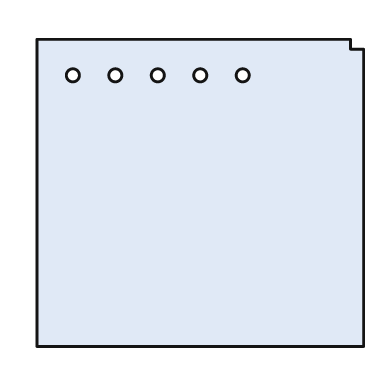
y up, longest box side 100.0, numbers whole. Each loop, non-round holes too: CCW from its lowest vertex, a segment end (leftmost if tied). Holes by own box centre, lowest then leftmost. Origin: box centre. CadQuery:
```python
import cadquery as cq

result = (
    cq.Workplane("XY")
    .moveTo(-50.0, -47.0)
    .lineTo(50.0, -47.0)
    .lineTo(50.0, 44.0)
    .lineTo(46.0, 44.0)
    .lineTo(46.0, 47.0)
    .lineTo(-50.0, 47.0)
    .close()
    .moveTo(-39.0, 36.0)
    .circle(2.0)
    .moveTo(-26.0, 36.0)
    .circle(2.0)
    .moveTo(-13.0, 36.0)
    .circle(2.0)
    .moveTo(0.0, 36.0)
    .circle(2.0)
    .moveTo(13.0, 36.0)
    .circle(2.0)
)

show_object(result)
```